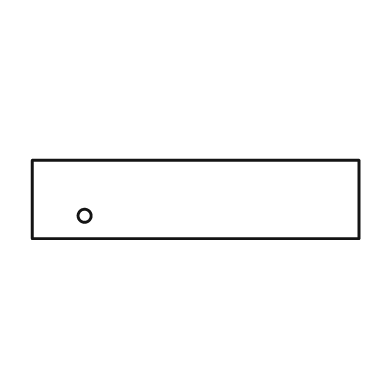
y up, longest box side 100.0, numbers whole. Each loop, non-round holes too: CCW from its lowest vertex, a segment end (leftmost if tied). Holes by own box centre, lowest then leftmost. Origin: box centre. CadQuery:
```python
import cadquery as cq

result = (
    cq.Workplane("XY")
    .moveTo(-50.0, -12.0)
    .lineTo(50.0, -12.0)
    .lineTo(50.0, 12.0)
    .lineTo(-50.0, 12.0)
    .close()
    .moveTo(-34.0, -5.0)
    .circle(2.0)
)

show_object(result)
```